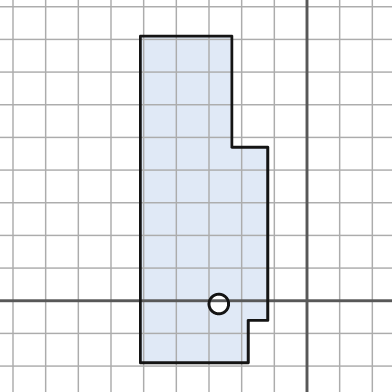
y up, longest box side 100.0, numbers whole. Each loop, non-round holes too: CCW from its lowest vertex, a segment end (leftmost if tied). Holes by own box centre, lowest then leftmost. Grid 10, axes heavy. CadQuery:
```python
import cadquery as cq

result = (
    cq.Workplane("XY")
    .moveTo(-51.0, -19.0)
    .lineTo(-18.0, -19.0)
    .lineTo(-18.0, -6.0)
    .lineTo(-12.0, -6.0)
    .lineTo(-12.0, 47.0)
    .lineTo(-23.0, 47.0)
    .lineTo(-23.0, 81.0)
    .lineTo(-51.0, 81.0)
    .close()
    .moveTo(-27.0, -1.0)
    .circle(3.0)
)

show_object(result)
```